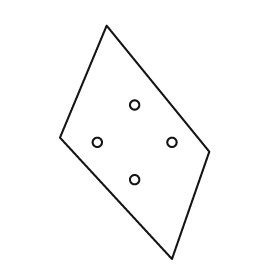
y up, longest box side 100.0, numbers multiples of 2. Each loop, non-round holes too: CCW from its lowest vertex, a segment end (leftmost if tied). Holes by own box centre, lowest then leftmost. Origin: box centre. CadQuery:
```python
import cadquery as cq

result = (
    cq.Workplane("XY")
    .moveTo(16.0, -50.0)
    .lineTo(32.0, -4.0)
    .lineTo(-12.0, 50.0)
    .lineTo(-32.0, 2.0)
    .close()
    .moveTo(0.0, -16.0)
    .circle(2.0)
    .moveTo(-16.0, 0.0)
    .circle(2.0)
    .moveTo(16.0, 0.0)
    .circle(2.0)
    .moveTo(0.0, 16.0)
    .circle(2.0)
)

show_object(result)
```